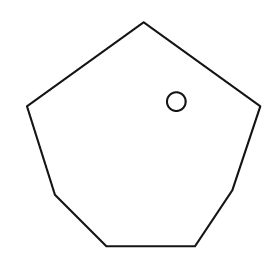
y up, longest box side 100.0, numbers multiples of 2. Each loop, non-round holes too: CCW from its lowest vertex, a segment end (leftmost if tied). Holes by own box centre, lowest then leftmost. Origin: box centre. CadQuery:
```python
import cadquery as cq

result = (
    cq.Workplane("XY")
    .moveTo(-16.0, -48.0)
    .lineTo(22.0, -48.0)
    .lineTo(38.0, -24.0)
    .lineTo(50.0, 12.0)
    .lineTo(0.0, 48.0)
    .lineTo(-50.0, 12.0)
    .lineTo(-38.0, -26.0)
    .close()
    .moveTo(14.0, 14.0)
    .circle(4.0)
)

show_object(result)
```